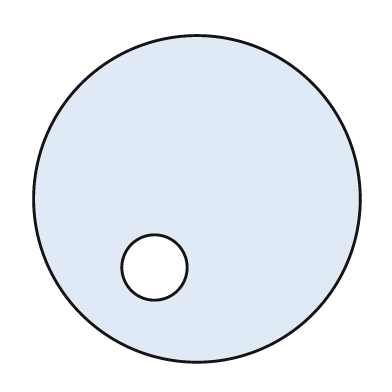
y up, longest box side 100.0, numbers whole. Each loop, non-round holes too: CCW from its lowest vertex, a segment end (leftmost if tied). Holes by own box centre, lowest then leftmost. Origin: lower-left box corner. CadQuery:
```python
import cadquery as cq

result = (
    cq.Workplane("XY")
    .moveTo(50.0, 50.0)
    .circle(50.0)
    .moveTo(37.0, 29.0)
    .circle(10.0)
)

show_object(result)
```